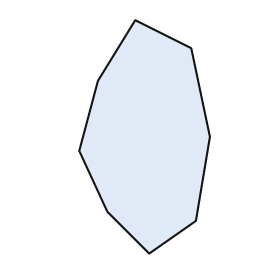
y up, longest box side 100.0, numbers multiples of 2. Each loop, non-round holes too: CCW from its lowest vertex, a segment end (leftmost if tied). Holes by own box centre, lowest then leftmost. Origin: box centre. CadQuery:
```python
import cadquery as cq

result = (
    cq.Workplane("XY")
    .moveTo(2.0, -50.0)
    .lineTo(22.0, -36.0)
    .lineTo(28.0, 0.0)
    .lineTo(20.0, 38.0)
    .lineTo(-4.0, 50.0)
    .lineTo(-20.0, 24.0)
    .lineTo(-28.0, -6.0)
    .lineTo(-16.0, -32.0)
    .close()
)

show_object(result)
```